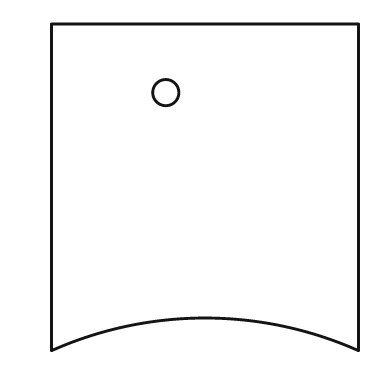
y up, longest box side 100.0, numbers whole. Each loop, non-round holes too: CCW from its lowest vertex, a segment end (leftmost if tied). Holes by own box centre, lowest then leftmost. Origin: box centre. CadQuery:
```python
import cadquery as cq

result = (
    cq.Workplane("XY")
    .moveTo(-47.0, -50.0)
    .threePointArc((0.0, -40.0), (47.0, -50.0))
    .lineTo(47.0, 50.0)
    .lineTo(-47.0, 50.0)
    .close()
    .moveTo(-12.0, 29.0)
    .circle(4.0)
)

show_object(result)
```